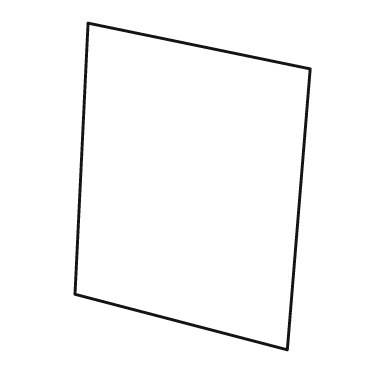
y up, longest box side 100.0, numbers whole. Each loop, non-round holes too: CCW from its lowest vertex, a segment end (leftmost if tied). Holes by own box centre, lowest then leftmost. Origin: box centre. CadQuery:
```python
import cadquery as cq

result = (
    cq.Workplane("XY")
    .moveTo(29.0, -50.0)
    .lineTo(36.0, 36.0)
    .lineTo(-32.0, 50.0)
    .lineTo(-36.0, -33.0)
    .close()
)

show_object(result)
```